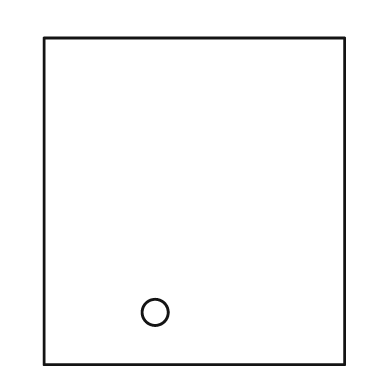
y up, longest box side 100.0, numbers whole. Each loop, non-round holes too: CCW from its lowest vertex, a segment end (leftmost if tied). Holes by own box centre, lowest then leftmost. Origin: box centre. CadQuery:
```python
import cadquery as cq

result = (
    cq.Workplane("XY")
    .moveTo(-46.0, -50.0)
    .lineTo(46.0, -50.0)
    .lineTo(46.0, 50.0)
    .lineTo(-46.0, 50.0)
    .close()
    .moveTo(-12.0, -34.0)
    .circle(4.0)
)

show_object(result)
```